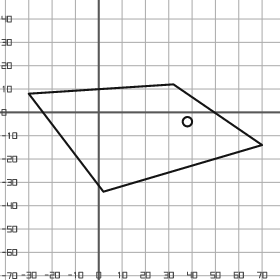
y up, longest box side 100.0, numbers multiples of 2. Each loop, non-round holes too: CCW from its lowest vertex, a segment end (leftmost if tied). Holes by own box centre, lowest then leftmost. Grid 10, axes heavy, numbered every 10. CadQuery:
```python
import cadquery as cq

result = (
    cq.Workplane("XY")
    .moveTo(2.0, -34.0)
    .lineTo(70.0, -14.0)
    .lineTo(32.0, 12.0)
    .lineTo(-30.0, 8.0)
    .close()
    .moveTo(38.0, -4.0)
    .circle(2.0)
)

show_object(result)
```